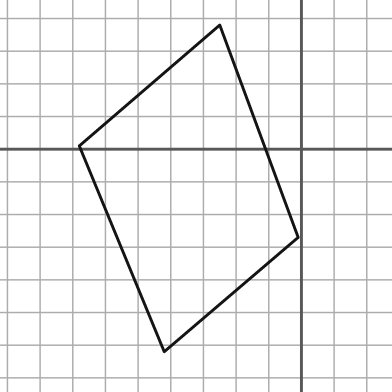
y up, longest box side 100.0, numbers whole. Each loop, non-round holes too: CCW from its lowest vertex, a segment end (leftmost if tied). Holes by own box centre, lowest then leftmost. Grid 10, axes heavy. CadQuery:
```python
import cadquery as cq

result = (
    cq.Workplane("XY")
    .moveTo(-42.0, -62.0)
    .lineTo(-1.0, -27.0)
    .lineTo(-25.0, 38.0)
    .lineTo(-68.0, 1.0)
    .close()
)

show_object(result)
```